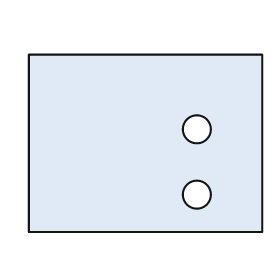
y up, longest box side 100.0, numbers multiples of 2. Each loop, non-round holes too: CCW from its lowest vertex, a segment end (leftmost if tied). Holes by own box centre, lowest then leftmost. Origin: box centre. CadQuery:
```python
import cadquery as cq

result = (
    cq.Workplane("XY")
    .moveTo(-50.0, -38.0)
    .lineTo(50.0, -38.0)
    .lineTo(50.0, 38.0)
    .lineTo(-50.0, 38.0)
    .close()
    .moveTo(22.0, -22.0)
    .circle(6.0)
    .moveTo(22.0, 6.0)
    .circle(6.0)
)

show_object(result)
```